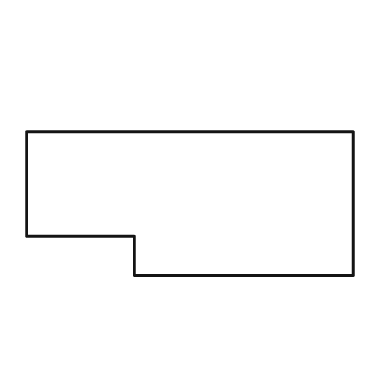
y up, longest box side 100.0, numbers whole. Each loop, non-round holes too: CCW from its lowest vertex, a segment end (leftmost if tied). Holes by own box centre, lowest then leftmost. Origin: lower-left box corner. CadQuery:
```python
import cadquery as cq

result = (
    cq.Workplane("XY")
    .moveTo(33.0, 0.0)
    .lineTo(100.0, 0.0)
    .lineTo(100.0, 44.0)
    .lineTo(0.0, 44.0)
    .lineTo(0.0, 12.0)
    .lineTo(33.0, 12.0)
    .close()
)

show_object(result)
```